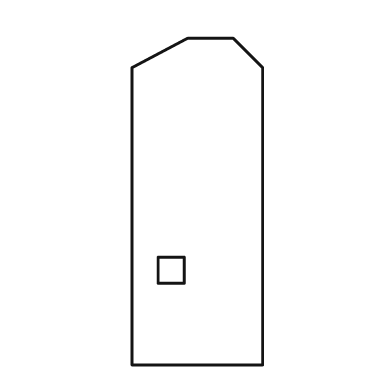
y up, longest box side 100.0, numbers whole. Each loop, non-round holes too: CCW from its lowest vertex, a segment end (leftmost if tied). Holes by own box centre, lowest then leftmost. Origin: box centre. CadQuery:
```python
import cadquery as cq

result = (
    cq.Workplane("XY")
    .moveTo(-20.0, -50.0)
    .lineTo(20.0, -50.0)
    .lineTo(20.0, 41.0)
    .lineTo(11.0, 50.0)
    .lineTo(-3.0, 50.0)
    .lineTo(-20.0, 41.0)
    .close()
    .moveTo(-12.0, -25.0)
    .lineTo(-4.0, -25.0)
    .lineTo(-4.0, -17.0)
    .lineTo(-12.0, -17.0)
    .close()
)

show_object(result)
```